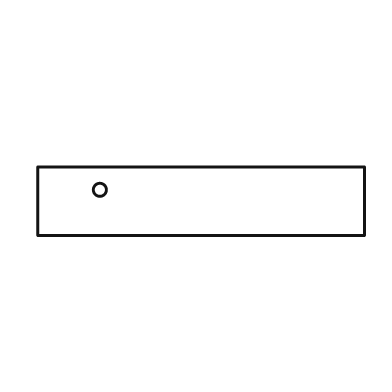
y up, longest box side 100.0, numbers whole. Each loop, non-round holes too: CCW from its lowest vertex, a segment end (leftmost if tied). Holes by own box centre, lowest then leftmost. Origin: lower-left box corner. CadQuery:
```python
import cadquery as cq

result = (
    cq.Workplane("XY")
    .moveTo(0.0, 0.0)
    .lineTo(100.0, 0.0)
    .lineTo(100.0, 21.0)
    .lineTo(0.0, 21.0)
    .close()
    .moveTo(19.0, 14.0)
    .circle(2.0)
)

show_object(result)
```